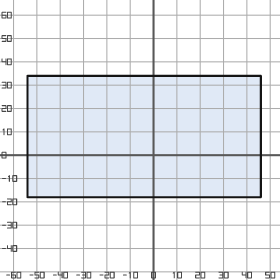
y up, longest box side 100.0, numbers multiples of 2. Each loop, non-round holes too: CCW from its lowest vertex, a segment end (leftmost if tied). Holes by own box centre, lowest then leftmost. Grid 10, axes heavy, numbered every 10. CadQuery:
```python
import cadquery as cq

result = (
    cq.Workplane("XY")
    .moveTo(-54.0, -18.0)
    .lineTo(46.0, -18.0)
    .lineTo(46.0, 34.0)
    .lineTo(-54.0, 34.0)
    .close()
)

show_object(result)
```